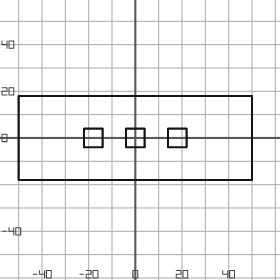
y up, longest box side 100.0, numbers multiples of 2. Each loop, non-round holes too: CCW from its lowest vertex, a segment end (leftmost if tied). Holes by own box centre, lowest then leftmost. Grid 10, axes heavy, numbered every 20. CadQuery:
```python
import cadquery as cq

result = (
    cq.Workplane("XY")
    .moveTo(-50.0, -18.0)
    .lineTo(50.0, -18.0)
    .lineTo(50.0, 18.0)
    .lineTo(-50.0, 18.0)
    .close()
    .moveTo(-22.0, -4.0)
    .lineTo(-14.0, -4.0)
    .lineTo(-14.0, 4.0)
    .lineTo(-22.0, 4.0)
    .close()
    .moveTo(-4.0, -4.0)
    .lineTo(4.0, -4.0)
    .lineTo(4.0, 4.0)
    .lineTo(-4.0, 4.0)
    .close()
    .moveTo(14.0, -4.0)
    .lineTo(22.0, -4.0)
    .lineTo(22.0, 4.0)
    .lineTo(14.0, 4.0)
    .close()
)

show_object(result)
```